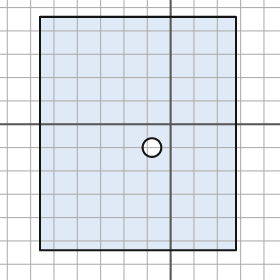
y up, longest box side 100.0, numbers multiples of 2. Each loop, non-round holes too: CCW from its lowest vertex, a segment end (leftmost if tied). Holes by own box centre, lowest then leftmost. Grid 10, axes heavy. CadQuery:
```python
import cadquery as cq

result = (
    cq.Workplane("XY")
    .moveTo(-56.0, -54.0)
    .lineTo(28.0, -54.0)
    .lineTo(28.0, 46.0)
    .lineTo(-56.0, 46.0)
    .close()
    .moveTo(-8.0, -10.0)
    .circle(4.0)
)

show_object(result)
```